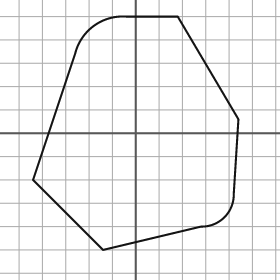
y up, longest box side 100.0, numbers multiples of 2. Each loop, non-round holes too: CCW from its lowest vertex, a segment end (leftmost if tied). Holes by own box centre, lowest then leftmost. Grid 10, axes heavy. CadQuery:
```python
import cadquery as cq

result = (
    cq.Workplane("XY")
    .moveTo(-14.0, -50.0)
    .lineTo(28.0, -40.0)
    .threePointArc((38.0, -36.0), (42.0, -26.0))
    .lineTo(44.0, 6.0)
    .lineTo(18.0, 50.0)
    .lineTo(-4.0, 50.0)
    .threePointArc((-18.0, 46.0), (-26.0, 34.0))
    .lineTo(-44.0, -20.0)
    .close()
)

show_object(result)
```